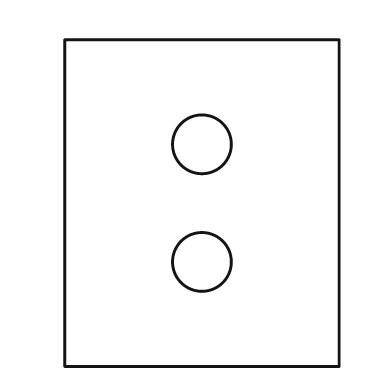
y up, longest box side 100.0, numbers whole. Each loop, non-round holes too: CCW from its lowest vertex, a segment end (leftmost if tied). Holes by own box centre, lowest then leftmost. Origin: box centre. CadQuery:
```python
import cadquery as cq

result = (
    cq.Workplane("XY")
    .moveTo(-42.0, -50.0)
    .lineTo(42.0, -50.0)
    .lineTo(42.0, 50.0)
    .lineTo(-42.0, 50.0)
    .close()
    .moveTo(0.0, -18.0)
    .circle(9.0)
    .moveTo(0.0, 18.0)
    .circle(9.0)
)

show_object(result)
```